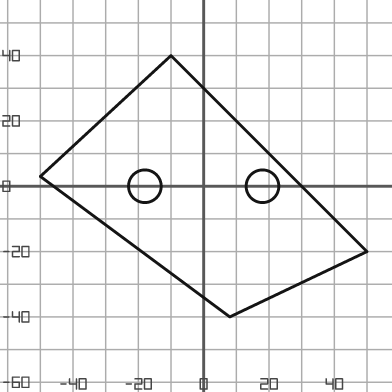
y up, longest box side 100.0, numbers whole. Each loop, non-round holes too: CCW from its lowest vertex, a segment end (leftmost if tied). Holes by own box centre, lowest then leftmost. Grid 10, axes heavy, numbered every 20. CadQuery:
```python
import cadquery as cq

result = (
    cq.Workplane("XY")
    .moveTo(8.0, -40.0)
    .lineTo(50.0, -20.0)
    .lineTo(-10.0, 40.0)
    .lineTo(-50.0, 3.0)
    .close()
    .moveTo(-18.0, 0.0)
    .circle(5.0)
    .moveTo(18.0, 0.0)
    .circle(5.0)
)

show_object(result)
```